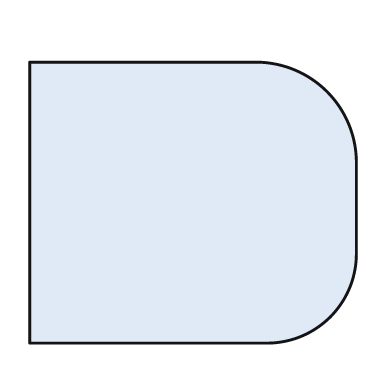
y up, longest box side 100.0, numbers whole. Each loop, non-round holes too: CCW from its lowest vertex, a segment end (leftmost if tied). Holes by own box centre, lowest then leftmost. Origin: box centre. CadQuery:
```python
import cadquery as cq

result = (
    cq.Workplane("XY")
    .moveTo(-50.0, -43.0)
    .lineTo(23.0, -43.0)
    .threePointArc((42.0, -35.0), (50.0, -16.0))
    .lineTo(50.0, 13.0)
    .threePointArc((41.0, 34.0), (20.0, 43.0))
    .lineTo(-50.0, 43.0)
    .close()
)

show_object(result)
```